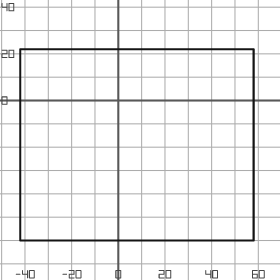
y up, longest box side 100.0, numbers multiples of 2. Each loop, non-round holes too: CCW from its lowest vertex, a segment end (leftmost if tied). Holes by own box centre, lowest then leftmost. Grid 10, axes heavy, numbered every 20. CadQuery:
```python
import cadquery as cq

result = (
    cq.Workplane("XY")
    .moveTo(-42.0, -60.0)
    .lineTo(58.0, -60.0)
    .lineTo(58.0, 22.0)
    .lineTo(-42.0, 22.0)
    .close()
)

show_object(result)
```